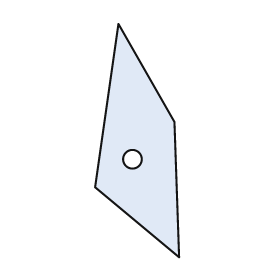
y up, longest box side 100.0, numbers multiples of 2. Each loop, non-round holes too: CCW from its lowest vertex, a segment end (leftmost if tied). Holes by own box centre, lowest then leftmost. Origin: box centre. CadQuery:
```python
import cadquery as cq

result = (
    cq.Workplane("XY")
    .moveTo(18.0, -50.0)
    .lineTo(16.0, 8.0)
    .lineTo(-8.0, 50.0)
    .lineTo(-18.0, -20.0)
    .close()
    .moveTo(-2.0, -8.0)
    .circle(4.0)
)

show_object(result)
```